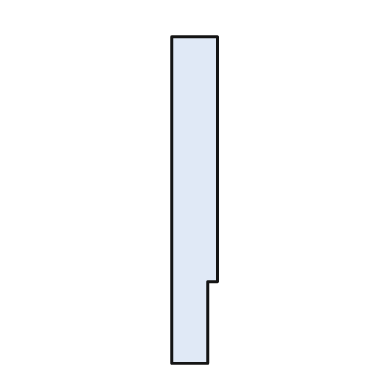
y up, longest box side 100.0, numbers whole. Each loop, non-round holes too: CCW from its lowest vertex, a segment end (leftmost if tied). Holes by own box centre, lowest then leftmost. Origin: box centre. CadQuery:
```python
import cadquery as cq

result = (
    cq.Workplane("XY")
    .moveTo(-7.0, -50.0)
    .lineTo(4.0, -50.0)
    .lineTo(4.0, -25.0)
    .lineTo(7.0, -25.0)
    .lineTo(7.0, 50.0)
    .lineTo(-7.0, 50.0)
    .close()
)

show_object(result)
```